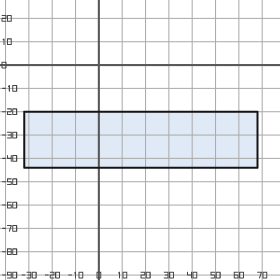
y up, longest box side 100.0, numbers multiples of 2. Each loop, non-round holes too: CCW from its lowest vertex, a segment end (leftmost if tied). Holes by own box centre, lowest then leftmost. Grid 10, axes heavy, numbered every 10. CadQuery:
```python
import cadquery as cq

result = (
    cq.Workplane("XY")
    .moveTo(-32.0, -44.0)
    .lineTo(68.0, -44.0)
    .lineTo(68.0, -20.0)
    .lineTo(-32.0, -20.0)
    .close()
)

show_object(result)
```